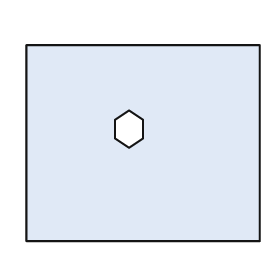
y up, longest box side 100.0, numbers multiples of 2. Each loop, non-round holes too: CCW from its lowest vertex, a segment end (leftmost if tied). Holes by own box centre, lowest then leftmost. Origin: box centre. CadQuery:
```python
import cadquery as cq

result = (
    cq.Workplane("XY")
    .moveTo(-50.0, -42.0)
    .lineTo(50.0, -42.0)
    .lineTo(50.0, 42.0)
    .lineTo(-50.0, 42.0)
    .close()
    .moveTo(-6.0, -2.0)
    .lineTo(0.0, 2.0)
    .lineTo(0.0, 10.0)
    .lineTo(-6.0, 14.0)
    .lineTo(-12.0, 10.0)
    .lineTo(-12.0, 2.0)
    .close()
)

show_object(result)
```